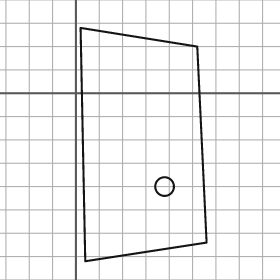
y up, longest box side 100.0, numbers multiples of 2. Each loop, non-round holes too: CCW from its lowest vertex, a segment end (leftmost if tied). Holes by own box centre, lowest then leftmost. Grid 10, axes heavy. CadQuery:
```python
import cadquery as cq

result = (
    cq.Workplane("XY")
    .moveTo(4.0, -72.0)
    .lineTo(56.0, -64.0)
    .lineTo(52.0, 20.0)
    .lineTo(2.0, 28.0)
    .close()
    .moveTo(38.0, -40.0)
    .circle(4.0)
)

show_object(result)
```